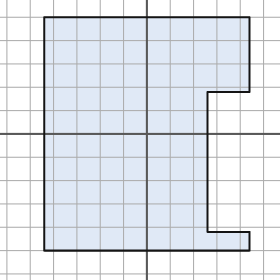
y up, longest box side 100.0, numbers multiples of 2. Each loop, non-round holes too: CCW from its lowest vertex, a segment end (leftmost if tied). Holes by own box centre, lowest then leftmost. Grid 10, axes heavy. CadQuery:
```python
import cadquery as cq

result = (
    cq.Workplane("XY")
    .moveTo(-44.0, -50.0)
    .lineTo(44.0, -50.0)
    .lineTo(44.0, -42.0)
    .lineTo(26.0, -42.0)
    .lineTo(26.0, 18.0)
    .lineTo(44.0, 18.0)
    .lineTo(44.0, 50.0)
    .lineTo(-44.0, 50.0)
    .close()
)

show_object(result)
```